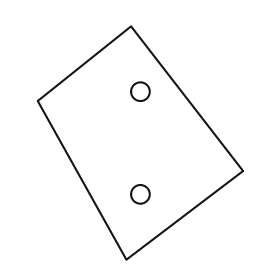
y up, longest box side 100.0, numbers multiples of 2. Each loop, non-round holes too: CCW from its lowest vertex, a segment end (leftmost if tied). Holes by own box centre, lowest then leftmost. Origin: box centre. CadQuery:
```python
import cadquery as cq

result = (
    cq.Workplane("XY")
    .moveTo(-6.0, -50.0)
    .lineTo(44.0, -12.0)
    .lineTo(-4.0, 50.0)
    .lineTo(-44.0, 18.0)
    .close()
    .moveTo(0.0, -22.0)
    .circle(4.0)
    .moveTo(0.0, 22.0)
    .circle(4.0)
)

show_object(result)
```